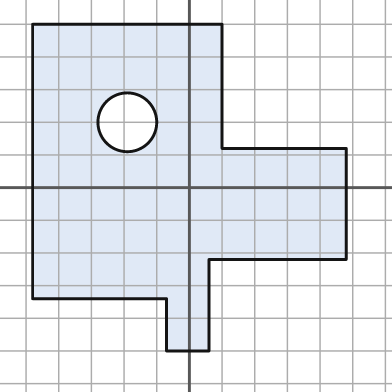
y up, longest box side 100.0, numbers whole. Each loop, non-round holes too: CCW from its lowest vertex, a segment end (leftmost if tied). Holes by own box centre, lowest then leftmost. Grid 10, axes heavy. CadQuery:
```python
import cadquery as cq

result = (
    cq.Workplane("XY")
    .moveTo(-7.0, -50.0)
    .lineTo(6.0, -50.0)
    .lineTo(6.0, -22.0)
    .lineTo(48.0, -22.0)
    .lineTo(48.0, 12.0)
    .lineTo(10.0, 12.0)
    .lineTo(10.0, 50.0)
    .lineTo(-48.0, 50.0)
    .lineTo(-48.0, -34.0)
    .lineTo(-7.0, -34.0)
    .close()
    .moveTo(-19.0, 20.0)
    .circle(9.0)
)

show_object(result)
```